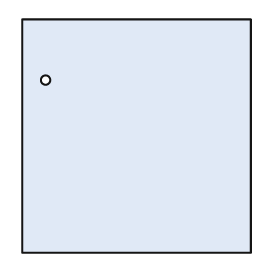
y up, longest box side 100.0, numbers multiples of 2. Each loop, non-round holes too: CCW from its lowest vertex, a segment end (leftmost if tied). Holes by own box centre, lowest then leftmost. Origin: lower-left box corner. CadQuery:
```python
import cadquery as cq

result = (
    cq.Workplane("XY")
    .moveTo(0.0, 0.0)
    .lineTo(98.0, 0.0)
    .lineTo(98.0, 100.0)
    .lineTo(0.0, 100.0)
    .close()
    .moveTo(10.0, 74.0)
    .circle(2.0)
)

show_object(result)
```